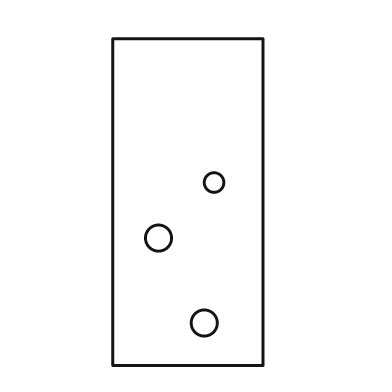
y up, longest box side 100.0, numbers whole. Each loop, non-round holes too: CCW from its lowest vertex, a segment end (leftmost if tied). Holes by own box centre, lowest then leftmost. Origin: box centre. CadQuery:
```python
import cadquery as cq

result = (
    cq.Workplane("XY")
    .moveTo(-23.0, -50.0)
    .lineTo(23.0, -50.0)
    .lineTo(23.0, 50.0)
    .lineTo(-23.0, 50.0)
    .close()
    .moveTo(5.0, -37.0)
    .circle(4.0)
    .moveTo(-9.0, -11.0)
    .circle(4.0)
    .moveTo(8.0, 6.0)
    .circle(3.0)
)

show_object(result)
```